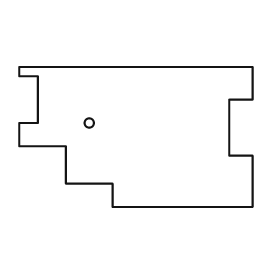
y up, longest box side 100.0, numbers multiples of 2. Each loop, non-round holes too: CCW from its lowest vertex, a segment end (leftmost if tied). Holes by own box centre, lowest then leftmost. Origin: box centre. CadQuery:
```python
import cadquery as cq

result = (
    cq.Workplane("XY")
    .moveTo(-10.0, -30.0)
    .lineTo(50.0, -30.0)
    .lineTo(50.0, -8.0)
    .lineTo(40.0, -8.0)
    .lineTo(40.0, 16.0)
    .lineTo(50.0, 16.0)
    .lineTo(50.0, 30.0)
    .lineTo(-50.0, 30.0)
    .lineTo(-50.0, 26.0)
    .lineTo(-42.0, 26.0)
    .lineTo(-42.0, 6.0)
    .lineTo(-50.0, 6.0)
    .lineTo(-50.0, -4.0)
    .lineTo(-30.0, -4.0)
    .lineTo(-30.0, -20.0)
    .lineTo(-10.0, -20.0)
    .close()
    .moveTo(-20.0, 6.0)
    .circle(2.0)
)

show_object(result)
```